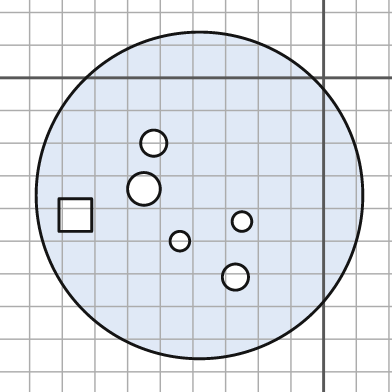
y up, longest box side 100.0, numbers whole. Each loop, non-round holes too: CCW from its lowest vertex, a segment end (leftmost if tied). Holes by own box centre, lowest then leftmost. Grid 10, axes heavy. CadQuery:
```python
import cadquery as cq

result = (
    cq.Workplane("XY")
    .moveTo(-38.0, -36.0)
    .circle(50.0)
    .moveTo(-27.0, -61.0)
    .circle(4.0)
    .moveTo(-44.0, -50.0)
    .circle(3.0)
    .moveTo(-25.0, -44.0)
    .circle(3.0)
    .moveTo(-81.0, -47.0)
    .lineTo(-71.0, -47.0)
    .lineTo(-71.0, -37.0)
    .lineTo(-81.0, -37.0)
    .close()
    .moveTo(-55.0, -34.0)
    .circle(5.0)
    .moveTo(-52.0, -20.0)
    .circle(4.0)
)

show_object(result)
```